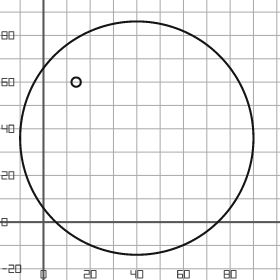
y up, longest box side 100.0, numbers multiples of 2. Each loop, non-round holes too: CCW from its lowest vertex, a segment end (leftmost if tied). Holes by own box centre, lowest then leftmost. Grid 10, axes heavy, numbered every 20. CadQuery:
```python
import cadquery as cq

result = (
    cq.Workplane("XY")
    .moveTo(40.0, 36.0)
    .circle(50.0)
    .moveTo(14.0, 60.0)
    .circle(2.0)
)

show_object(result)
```